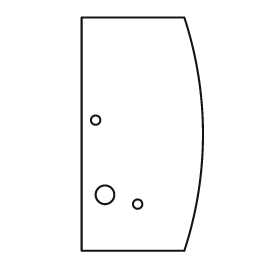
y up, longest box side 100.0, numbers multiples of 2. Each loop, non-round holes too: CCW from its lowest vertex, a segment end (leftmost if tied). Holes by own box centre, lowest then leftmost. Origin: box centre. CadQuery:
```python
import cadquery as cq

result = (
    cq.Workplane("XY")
    .moveTo(-26.0, -50.0)
    .lineTo(18.0, -50.0)
    .threePointArc((26.0, 0.0), (18.0, 50.0))
    .lineTo(-26.0, 50.0)
    .close()
    .moveTo(-2.0, -30.0)
    .circle(2.0)
    .moveTo(-16.0, -26.0)
    .circle(4.0)
    .moveTo(-20.0, 6.0)
    .circle(2.0)
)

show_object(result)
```